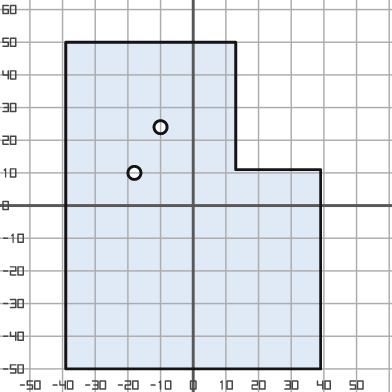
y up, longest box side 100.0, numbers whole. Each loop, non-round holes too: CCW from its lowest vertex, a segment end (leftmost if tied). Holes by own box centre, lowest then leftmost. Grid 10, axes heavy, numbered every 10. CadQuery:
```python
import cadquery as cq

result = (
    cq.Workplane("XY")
    .moveTo(-39.0, -50.0)
    .lineTo(39.0, -50.0)
    .lineTo(39.0, 11.0)
    .lineTo(13.0, 11.0)
    .lineTo(13.0, 50.0)
    .lineTo(-39.0, 50.0)
    .close()
    .moveTo(-18.0, 10.0)
    .circle(2.0)
    .moveTo(-10.0, 24.0)
    .circle(2.0)
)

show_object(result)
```